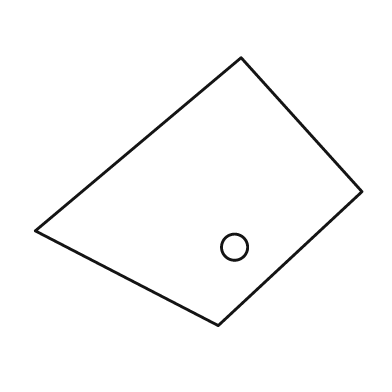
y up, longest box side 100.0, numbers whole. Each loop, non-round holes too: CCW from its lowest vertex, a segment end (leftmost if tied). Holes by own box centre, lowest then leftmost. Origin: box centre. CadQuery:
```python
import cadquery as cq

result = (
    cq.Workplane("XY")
    .moveTo(6.0, -41.0)
    .lineTo(50.0, 0.0)
    .lineTo(13.0, 41.0)
    .lineTo(-50.0, -12.0)
    .close()
    .moveTo(11.0, -17.0)
    .circle(4.0)
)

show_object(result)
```